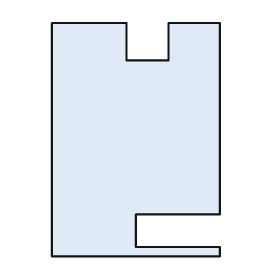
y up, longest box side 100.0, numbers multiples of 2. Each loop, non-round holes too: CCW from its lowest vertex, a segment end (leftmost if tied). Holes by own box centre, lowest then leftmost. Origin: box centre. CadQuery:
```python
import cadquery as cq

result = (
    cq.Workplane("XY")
    .moveTo(-36.0, -50.0)
    .lineTo(36.0, -50.0)
    .lineTo(36.0, -46.0)
    .lineTo(0.0, -46.0)
    .lineTo(0.0, -32.0)
    .lineTo(36.0, -32.0)
    .lineTo(36.0, 50.0)
    .lineTo(14.0, 50.0)
    .lineTo(14.0, 34.0)
    .lineTo(-4.0, 34.0)
    .lineTo(-4.0, 50.0)
    .lineTo(-36.0, 50.0)
    .close()
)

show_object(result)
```